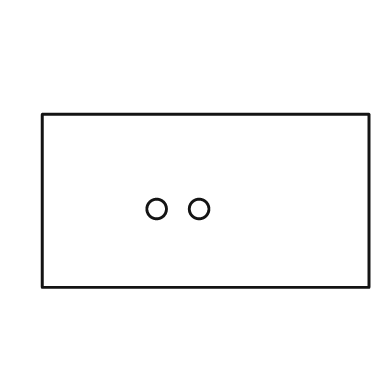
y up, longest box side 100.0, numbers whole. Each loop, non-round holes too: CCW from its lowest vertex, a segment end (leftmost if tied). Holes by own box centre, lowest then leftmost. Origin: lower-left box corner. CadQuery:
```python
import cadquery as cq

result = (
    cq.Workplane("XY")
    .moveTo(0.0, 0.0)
    .lineTo(100.0, 0.0)
    .lineTo(100.0, 53.0)
    .lineTo(0.0, 53.0)
    .close()
    .moveTo(35.0, 24.0)
    .circle(3.0)
    .moveTo(48.0, 24.0)
    .circle(3.0)
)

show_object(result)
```